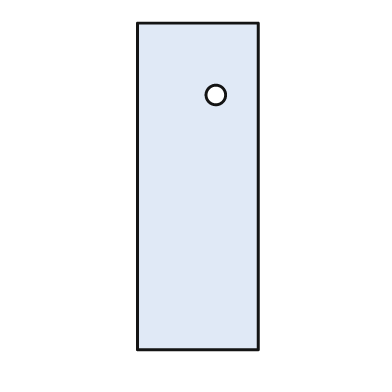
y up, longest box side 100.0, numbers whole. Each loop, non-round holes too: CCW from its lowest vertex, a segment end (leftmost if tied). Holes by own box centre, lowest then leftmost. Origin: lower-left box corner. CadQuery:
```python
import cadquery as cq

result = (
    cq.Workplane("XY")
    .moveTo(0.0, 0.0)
    .lineTo(37.0, 0.0)
    .lineTo(37.0, 100.0)
    .lineTo(0.0, 100.0)
    .close()
    .moveTo(24.0, 78.0)
    .circle(3.0)
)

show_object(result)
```